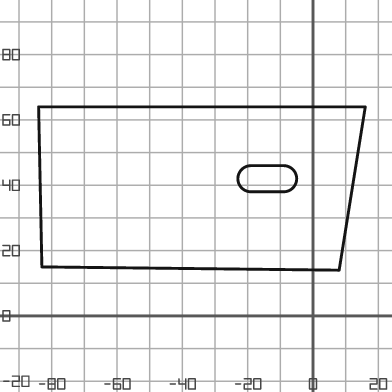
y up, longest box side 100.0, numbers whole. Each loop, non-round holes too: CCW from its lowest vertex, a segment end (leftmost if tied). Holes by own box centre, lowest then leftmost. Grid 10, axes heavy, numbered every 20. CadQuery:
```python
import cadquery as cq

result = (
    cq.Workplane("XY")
    .moveTo(8.0, 14.0)
    .lineTo(16.0, 64.0)
    .lineTo(-84.0, 64.0)
    .lineTo(-83.0, 15.0)
    .close()
    .moveTo(-19.0, 38.0)
    .lineTo(-9.0, 38.0)
    .threePointArc((-5.0, 42.0), (-9.0, 46.0))
    .lineTo(-19.0, 46.0)
    .threePointArc((-23.0, 42.0), (-19.0, 38.0))
    .close()
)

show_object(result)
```